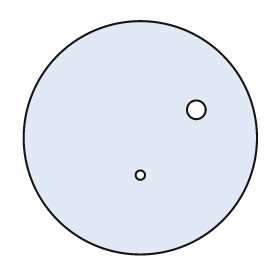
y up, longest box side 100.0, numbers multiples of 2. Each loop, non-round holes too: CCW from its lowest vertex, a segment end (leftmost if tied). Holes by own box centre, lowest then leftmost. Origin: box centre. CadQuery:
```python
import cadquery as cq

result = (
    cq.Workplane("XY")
    .moveTo(0.0, 0.0)
    .circle(50.0)
    .moveTo(0.0, -16.0)
    .circle(2.0)
    .moveTo(24.0, 12.0)
    .circle(4.0)
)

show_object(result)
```